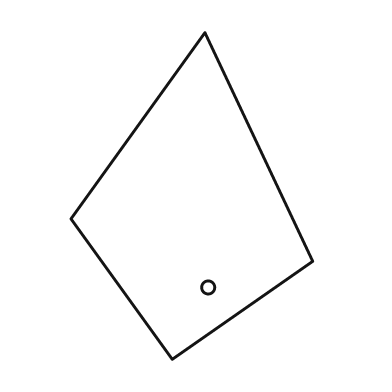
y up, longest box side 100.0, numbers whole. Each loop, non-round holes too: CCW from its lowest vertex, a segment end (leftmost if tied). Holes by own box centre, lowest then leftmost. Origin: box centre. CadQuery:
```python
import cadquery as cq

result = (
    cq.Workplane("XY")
    .moveTo(-6.0, -50.0)
    .lineTo(37.0, -20.0)
    .lineTo(4.0, 50.0)
    .lineTo(-37.0, -7.0)
    .close()
    .moveTo(5.0, -28.0)
    .circle(2.0)
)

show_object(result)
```